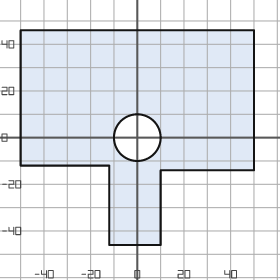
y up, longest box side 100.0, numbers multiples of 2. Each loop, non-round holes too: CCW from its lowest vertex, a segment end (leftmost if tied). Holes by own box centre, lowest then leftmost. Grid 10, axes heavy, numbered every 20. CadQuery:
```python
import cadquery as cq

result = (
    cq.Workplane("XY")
    .moveTo(-12.0, -46.0)
    .lineTo(10.0, -46.0)
    .lineTo(10.0, -14.0)
    .lineTo(50.0, -14.0)
    .lineTo(50.0, 46.0)
    .lineTo(-50.0, 46.0)
    .lineTo(-50.0, -12.0)
    .lineTo(-12.0, -12.0)
    .close()
    .moveTo(0.0, 0.0)
    .circle(10.0)
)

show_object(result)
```